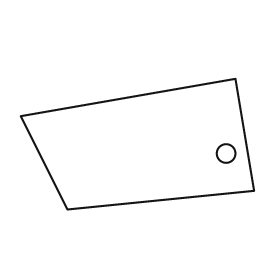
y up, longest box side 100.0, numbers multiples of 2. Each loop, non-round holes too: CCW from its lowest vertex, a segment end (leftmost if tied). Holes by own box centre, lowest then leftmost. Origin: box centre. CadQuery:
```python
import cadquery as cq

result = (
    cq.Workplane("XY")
    .moveTo(-30.0, -28.0)
    .lineTo(50.0, -20.0)
    .lineTo(42.0, 28.0)
    .lineTo(-50.0, 12.0)
    .close()
    .moveTo(38.0, -4.0)
    .circle(4.0)
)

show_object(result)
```